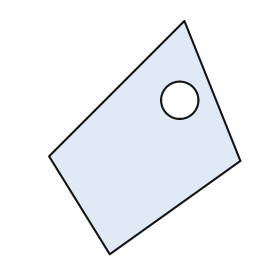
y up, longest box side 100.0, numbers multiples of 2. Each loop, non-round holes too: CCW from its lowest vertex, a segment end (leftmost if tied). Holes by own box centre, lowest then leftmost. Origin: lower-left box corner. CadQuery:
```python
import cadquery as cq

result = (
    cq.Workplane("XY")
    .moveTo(26.0, 0.0)
    .lineTo(82.0, 40.0)
    .lineTo(58.0, 100.0)
    .lineTo(0.0, 42.0)
    .close()
    .moveTo(56.0, 66.0)
    .circle(8.0)
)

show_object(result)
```